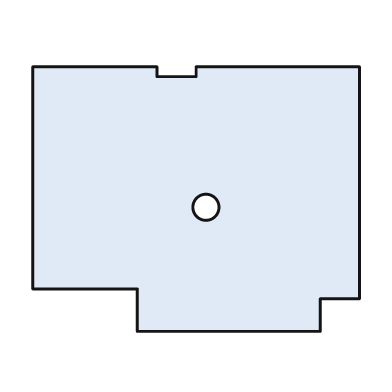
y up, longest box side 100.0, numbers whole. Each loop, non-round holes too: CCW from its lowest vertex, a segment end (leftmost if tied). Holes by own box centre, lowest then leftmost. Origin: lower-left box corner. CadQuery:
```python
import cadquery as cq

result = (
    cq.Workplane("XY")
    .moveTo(32.0, 0.0)
    .lineTo(88.0, 0.0)
    .lineTo(88.0, 10.0)
    .lineTo(100.0, 10.0)
    .lineTo(100.0, 81.0)
    .lineTo(50.0, 81.0)
    .lineTo(50.0, 78.0)
    .lineTo(38.0, 78.0)
    .lineTo(38.0, 81.0)
    .lineTo(0.0, 81.0)
    .lineTo(0.0, 13.0)
    .lineTo(32.0, 13.0)
    .close()
    .moveTo(53.0, 38.0)
    .circle(4.0)
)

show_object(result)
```